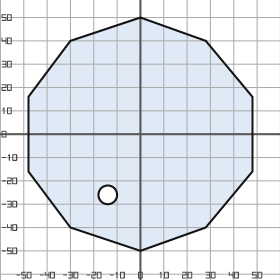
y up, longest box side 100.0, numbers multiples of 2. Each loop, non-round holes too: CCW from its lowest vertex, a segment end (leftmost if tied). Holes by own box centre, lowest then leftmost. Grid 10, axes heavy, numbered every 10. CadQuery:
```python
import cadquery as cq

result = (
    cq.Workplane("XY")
    .moveTo(0.0, -50.0)
    .lineTo(28.0, -40.0)
    .lineTo(48.0, -16.0)
    .lineTo(48.0, 16.0)
    .lineTo(28.0, 40.0)
    .lineTo(0.0, 50.0)
    .lineTo(-30.0, 40.0)
    .lineTo(-48.0, 16.0)
    .lineTo(-48.0, -16.0)
    .lineTo(-30.0, -40.0)
    .close()
    .moveTo(-14.0, -26.0)
    .circle(4.0)
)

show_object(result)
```